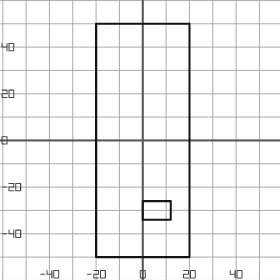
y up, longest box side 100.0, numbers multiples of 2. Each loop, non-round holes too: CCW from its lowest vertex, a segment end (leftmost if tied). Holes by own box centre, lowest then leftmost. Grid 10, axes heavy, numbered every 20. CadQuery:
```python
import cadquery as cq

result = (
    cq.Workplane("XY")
    .moveTo(-20.0, -50.0)
    .lineTo(20.0, -50.0)
    .lineTo(20.0, 50.0)
    .lineTo(-20.0, 50.0)
    .close()
    .moveTo(0.0, -34.0)
    .lineTo(12.0, -34.0)
    .lineTo(12.0, -26.0)
    .lineTo(0.0, -26.0)
    .close()
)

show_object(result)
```